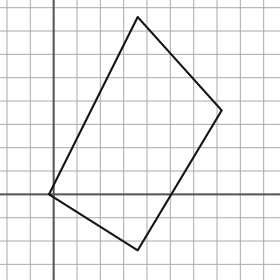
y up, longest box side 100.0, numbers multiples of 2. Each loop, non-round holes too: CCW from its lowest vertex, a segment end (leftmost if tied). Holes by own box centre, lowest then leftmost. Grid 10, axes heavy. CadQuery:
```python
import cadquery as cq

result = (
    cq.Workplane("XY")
    .moveTo(36.0, -24.0)
    .lineTo(72.0, 36.0)
    .lineTo(36.0, 76.0)
    .lineTo(-2.0, 0.0)
    .close()
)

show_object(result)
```